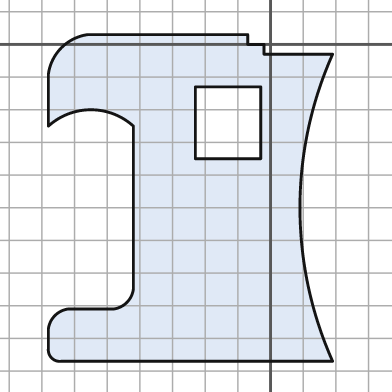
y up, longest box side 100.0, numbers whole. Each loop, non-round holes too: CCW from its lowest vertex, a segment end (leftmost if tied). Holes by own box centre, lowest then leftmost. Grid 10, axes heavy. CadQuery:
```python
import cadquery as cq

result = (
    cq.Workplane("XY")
    .moveTo(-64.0, -97.0)
    .lineTo(19.0, -97.0)
    .threePointArc((9.0, -50.0), (19.0, -3.0))
    .lineTo(-2.0, -3.0)
    .lineTo(-2.0, 0.0)
    .lineTo(-7.0, 0.0)
    .lineTo(-7.0, 3.0)
    .lineTo(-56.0, 3.0)
    .threePointArc((-64.0, -1.0), (-68.0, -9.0))
    .lineTo(-68.0, -25.0)
    .threePointArc((-55.0, -20.0), (-42.0, -25.0))
    .lineTo(-42.0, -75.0)
    .threePointArc((-44.0, -79.0), (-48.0, -81.0))
    .lineTo(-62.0, -81.0)
    .threePointArc((-66.0, -83.0), (-68.0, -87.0))
    .lineTo(-68.0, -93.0)
    .threePointArc((-67.0, -96.0), (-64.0, -97.0))
    .close()
    .moveTo(-23.0, -35.0)
    .lineTo(-3.0, -35.0)
    .lineTo(-3.0, -13.0)
    .lineTo(-23.0, -13.0)
    .close()
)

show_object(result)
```